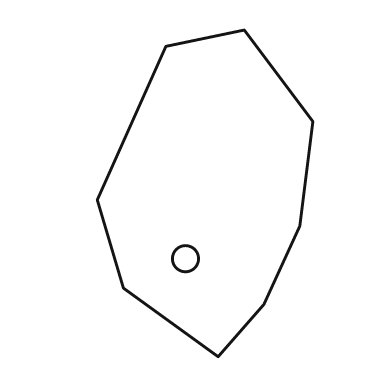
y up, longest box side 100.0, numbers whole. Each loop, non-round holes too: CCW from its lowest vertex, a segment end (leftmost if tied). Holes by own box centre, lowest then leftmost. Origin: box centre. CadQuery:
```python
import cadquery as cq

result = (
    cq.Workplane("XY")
    .moveTo(4.0, -50.0)
    .lineTo(18.0, -34.0)
    .lineTo(29.0, -10.0)
    .lineTo(33.0, 22.0)
    .lineTo(12.0, 50.0)
    .lineTo(-12.0, 45.0)
    .lineTo(-33.0, -2.0)
    .lineTo(-25.0, -29.0)
    .close()
    .moveTo(-6.0, -20.0)
    .circle(4.0)
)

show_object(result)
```